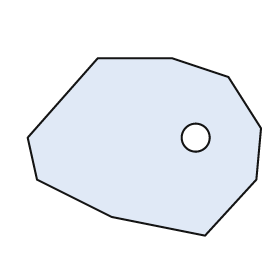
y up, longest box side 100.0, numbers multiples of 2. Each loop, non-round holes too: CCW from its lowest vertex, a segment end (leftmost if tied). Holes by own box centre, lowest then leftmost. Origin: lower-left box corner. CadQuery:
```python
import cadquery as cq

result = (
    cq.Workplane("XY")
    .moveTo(76.0, 0.0)
    .lineTo(98.0, 24.0)
    .lineTo(100.0, 46.0)
    .lineTo(86.0, 68.0)
    .lineTo(62.0, 76.0)
    .lineTo(30.0, 76.0)
    .lineTo(0.0, 42.0)
    .lineTo(4.0, 24.0)
    .lineTo(36.0, 8.0)
    .close()
    .moveTo(72.0, 42.0)
    .circle(6.0)
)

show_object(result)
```